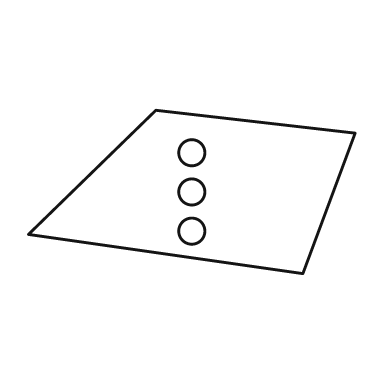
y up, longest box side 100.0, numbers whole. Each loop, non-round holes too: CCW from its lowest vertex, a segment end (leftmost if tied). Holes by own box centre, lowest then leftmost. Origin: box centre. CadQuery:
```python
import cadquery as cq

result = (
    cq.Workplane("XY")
    .moveTo(34.0, -25.0)
    .lineTo(50.0, 18.0)
    .lineTo(-11.0, 25.0)
    .lineTo(-50.0, -13.0)
    .close()
    .moveTo(0.0, -12.0)
    .circle(4.0)
    .moveTo(0.0, 0.0)
    .circle(4.0)
    .moveTo(0.0, 12.0)
    .circle(4.0)
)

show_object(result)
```